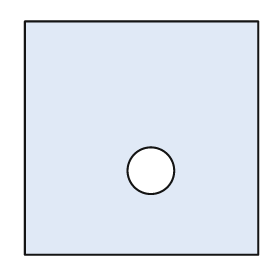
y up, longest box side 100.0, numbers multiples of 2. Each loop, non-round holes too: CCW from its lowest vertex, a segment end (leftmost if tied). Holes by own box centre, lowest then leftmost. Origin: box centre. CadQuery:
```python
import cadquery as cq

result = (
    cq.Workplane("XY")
    .moveTo(-50.0, -50.0)
    .lineTo(50.0, -50.0)
    .lineTo(50.0, 50.0)
    .lineTo(-50.0, 50.0)
    .close()
    .moveTo(4.0, -14.0)
    .circle(10.0)
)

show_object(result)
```